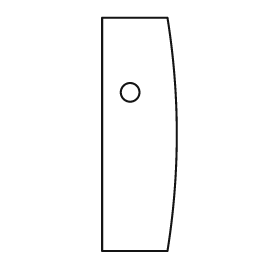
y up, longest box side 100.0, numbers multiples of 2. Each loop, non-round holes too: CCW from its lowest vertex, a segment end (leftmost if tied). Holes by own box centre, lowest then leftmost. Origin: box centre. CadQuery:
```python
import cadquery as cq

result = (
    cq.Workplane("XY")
    .moveTo(-16.0, -50.0)
    .lineTo(12.0, -50.0)
    .threePointArc((16.0, 0.0), (12.0, 50.0))
    .lineTo(-16.0, 50.0)
    .close()
    .moveTo(-4.0, 18.0)
    .circle(4.0)
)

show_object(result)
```